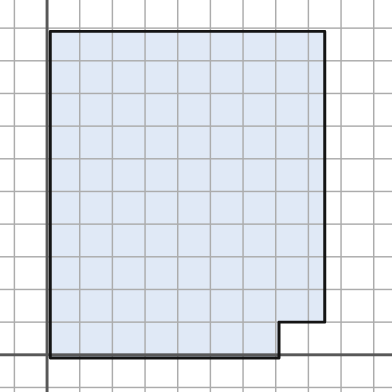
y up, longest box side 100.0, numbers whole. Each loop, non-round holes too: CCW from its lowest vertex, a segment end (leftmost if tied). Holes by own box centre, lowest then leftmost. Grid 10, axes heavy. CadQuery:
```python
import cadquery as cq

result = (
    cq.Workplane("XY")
    .moveTo(1.0, -1.0)
    .lineTo(71.0, -1.0)
    .lineTo(71.0, 10.0)
    .lineTo(85.0, 10.0)
    .lineTo(85.0, 99.0)
    .lineTo(1.0, 99.0)
    .close()
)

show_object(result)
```